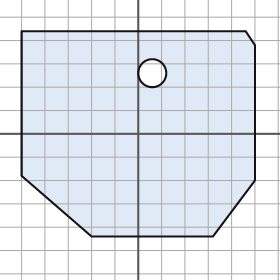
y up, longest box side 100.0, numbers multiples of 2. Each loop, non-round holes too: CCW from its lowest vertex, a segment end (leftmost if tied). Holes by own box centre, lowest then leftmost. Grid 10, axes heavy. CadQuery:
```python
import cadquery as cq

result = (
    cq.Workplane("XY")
    .moveTo(-20.0, -44.0)
    .lineTo(32.0, -44.0)
    .lineTo(50.0, -20.0)
    .lineTo(50.0, 38.0)
    .lineTo(46.0, 44.0)
    .lineTo(-50.0, 44.0)
    .lineTo(-50.0, -18.0)
    .close()
    .moveTo(6.0, 26.0)
    .circle(6.0)
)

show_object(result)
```